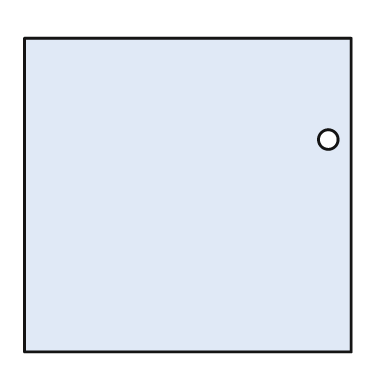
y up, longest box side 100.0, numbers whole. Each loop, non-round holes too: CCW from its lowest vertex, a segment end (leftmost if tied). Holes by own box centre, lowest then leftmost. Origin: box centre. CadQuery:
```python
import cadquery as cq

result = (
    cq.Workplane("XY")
    .moveTo(-50.0, -48.0)
    .lineTo(50.0, -48.0)
    .lineTo(50.0, 48.0)
    .lineTo(-50.0, 48.0)
    .close()
    .moveTo(43.0, 17.0)
    .circle(3.0)
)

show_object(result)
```